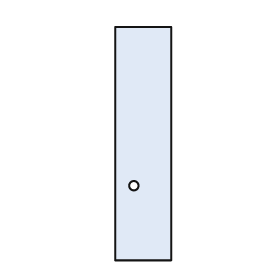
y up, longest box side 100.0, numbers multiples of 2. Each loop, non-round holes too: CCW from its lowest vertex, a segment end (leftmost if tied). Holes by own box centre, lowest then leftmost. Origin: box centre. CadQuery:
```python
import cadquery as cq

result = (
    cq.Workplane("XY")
    .moveTo(-12.0, -50.0)
    .lineTo(12.0, -50.0)
    .lineTo(12.0, 50.0)
    .lineTo(-12.0, 50.0)
    .close()
    .moveTo(-4.0, -18.0)
    .circle(2.0)
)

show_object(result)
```